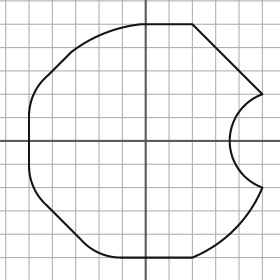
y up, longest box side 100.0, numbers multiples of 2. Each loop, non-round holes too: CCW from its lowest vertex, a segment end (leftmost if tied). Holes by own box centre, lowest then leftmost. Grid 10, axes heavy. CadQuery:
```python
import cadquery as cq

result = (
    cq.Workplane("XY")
    .moveTo(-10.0, -50.0)
    .lineTo(20.0, -50.0)
    .threePointArc((38.0, -38.0), (50.0, -20.0))
    .threePointArc((36.0, 0.0), (50.0, 20.0))
    .lineTo(20.0, 50.0)
    .lineTo(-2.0, 50.0)
    .threePointArc((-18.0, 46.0), (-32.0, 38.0))
    .lineTo(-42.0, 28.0)
    .threePointArc((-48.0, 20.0), (-50.0, 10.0))
    .lineTo(-50.0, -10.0)
    .threePointArc((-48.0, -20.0), (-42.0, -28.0))
    .lineTo(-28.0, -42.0)
    .threePointArc((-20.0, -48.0), (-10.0, -50.0))
    .close()
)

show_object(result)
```